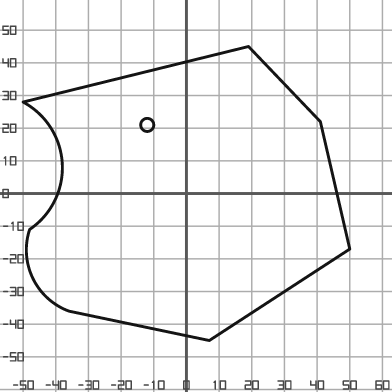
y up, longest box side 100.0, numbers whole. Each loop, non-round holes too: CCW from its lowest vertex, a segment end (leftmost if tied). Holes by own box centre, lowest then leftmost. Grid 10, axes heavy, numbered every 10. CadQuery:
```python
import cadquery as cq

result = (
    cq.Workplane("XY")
    .moveTo(7.0, -45.0)
    .lineTo(50.0, -17.0)
    .lineTo(41.0, 22.0)
    .lineTo(19.0, 45.0)
    .lineTo(-50.0, 28.0)
    .threePointArc((-38.0, 9.0), (-48.0, -11.0))
    .threePointArc((-47.0, -26.0), (-36.0, -36.0))
    .close()
    .moveTo(-12.0, 21.0)
    .circle(2.0)
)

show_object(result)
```